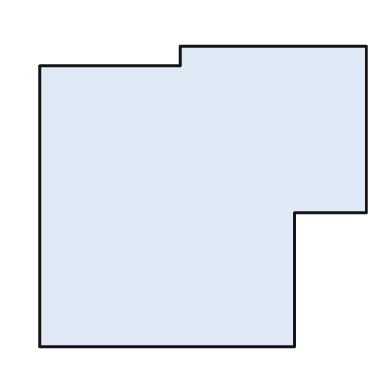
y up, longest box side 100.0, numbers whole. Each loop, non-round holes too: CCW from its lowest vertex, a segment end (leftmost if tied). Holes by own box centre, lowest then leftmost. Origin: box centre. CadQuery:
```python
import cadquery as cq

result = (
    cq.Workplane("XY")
    .moveTo(-50.0, -46.0)
    .lineTo(28.0, -46.0)
    .lineTo(28.0, -5.0)
    .lineTo(50.0, -5.0)
    .lineTo(50.0, 46.0)
    .lineTo(-7.0, 46.0)
    .lineTo(-7.0, 40.0)
    .lineTo(-50.0, 40.0)
    .close()
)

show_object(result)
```